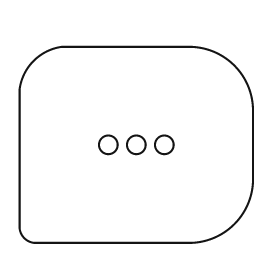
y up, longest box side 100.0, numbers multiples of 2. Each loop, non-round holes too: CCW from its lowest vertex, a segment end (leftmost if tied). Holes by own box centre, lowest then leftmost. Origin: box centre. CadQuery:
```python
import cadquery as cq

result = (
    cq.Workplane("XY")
    .moveTo(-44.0, -42.0)
    .lineTo(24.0, -42.0)
    .threePointArc((42.0, -34.0), (50.0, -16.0))
    .lineTo(50.0, 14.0)
    .threePointArc((42.0, 34.0), (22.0, 42.0))
    .lineTo(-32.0, 42.0)
    .threePointArc((-44.0, 36.0), (-50.0, 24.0))
    .lineTo(-50.0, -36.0)
    .threePointArc((-48.0, -40.0), (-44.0, -42.0))
    .close()
    .moveTo(-12.0, 0.0)
    .circle(4.0)
    .moveTo(0.0, 0.0)
    .circle(4.0)
    .moveTo(12.0, 0.0)
    .circle(4.0)
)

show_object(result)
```